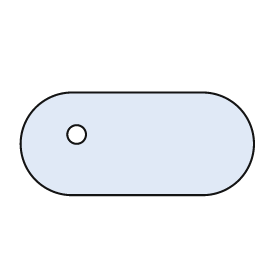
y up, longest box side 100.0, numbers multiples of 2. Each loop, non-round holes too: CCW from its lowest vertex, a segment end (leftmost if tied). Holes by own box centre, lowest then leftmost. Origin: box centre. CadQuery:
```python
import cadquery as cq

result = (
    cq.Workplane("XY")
    .moveTo(-28.0, -22.0)
    .lineTo(28.0, -22.0)
    .threePointArc((50.0, 0.0), (28.0, 22.0))
    .lineTo(-28.0, 22.0)
    .threePointArc((-50.0, 0.0), (-28.0, -22.0))
    .close()
    .moveTo(-26.0, 4.0)
    .circle(4.0)
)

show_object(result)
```